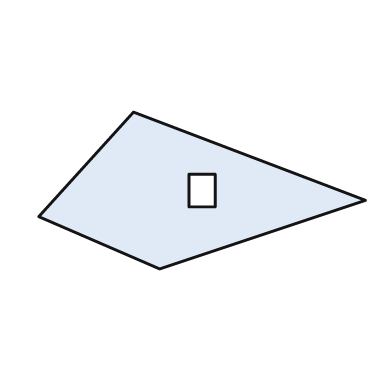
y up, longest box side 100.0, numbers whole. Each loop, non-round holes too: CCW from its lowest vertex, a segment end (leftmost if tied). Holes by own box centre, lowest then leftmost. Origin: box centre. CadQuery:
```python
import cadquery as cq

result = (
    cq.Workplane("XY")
    .moveTo(-13.0, -24.0)
    .lineTo(50.0, -3.0)
    .lineTo(-21.0, 24.0)
    .lineTo(-50.0, -8.0)
    .close()
    .moveTo(-4.0, -5.0)
    .lineTo(4.0, -5.0)
    .lineTo(4.0, 5.0)
    .lineTo(-4.0, 5.0)
    .close()
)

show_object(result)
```